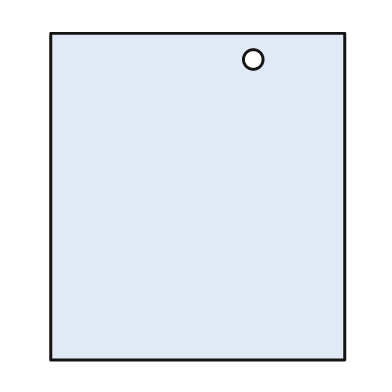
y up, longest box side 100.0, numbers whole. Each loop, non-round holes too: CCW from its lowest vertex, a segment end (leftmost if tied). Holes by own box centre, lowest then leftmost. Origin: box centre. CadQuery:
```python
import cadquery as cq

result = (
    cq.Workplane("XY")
    .moveTo(-45.0, -50.0)
    .lineTo(45.0, -50.0)
    .lineTo(45.0, 50.0)
    .lineTo(-45.0, 50.0)
    .close()
    .moveTo(17.0, 42.0)
    .circle(3.0)
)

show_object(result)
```